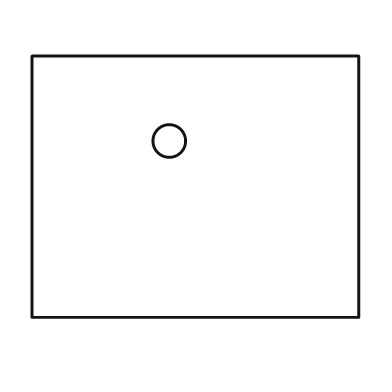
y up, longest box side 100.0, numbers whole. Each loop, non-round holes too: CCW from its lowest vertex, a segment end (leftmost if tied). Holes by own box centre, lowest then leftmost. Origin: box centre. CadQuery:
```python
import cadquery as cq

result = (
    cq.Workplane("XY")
    .moveTo(-50.0, -40.0)
    .lineTo(50.0, -40.0)
    .lineTo(50.0, 40.0)
    .lineTo(-50.0, 40.0)
    .close()
    .moveTo(-8.0, 14.0)
    .circle(5.0)
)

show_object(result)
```